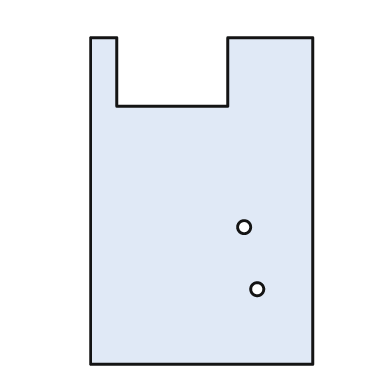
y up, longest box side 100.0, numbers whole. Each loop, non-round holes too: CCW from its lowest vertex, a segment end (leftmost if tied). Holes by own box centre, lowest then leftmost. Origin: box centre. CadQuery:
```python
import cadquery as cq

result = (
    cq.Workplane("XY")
    .moveTo(-34.0, -50.0)
    .lineTo(34.0, -50.0)
    .lineTo(34.0, 50.0)
    .lineTo(8.0, 50.0)
    .lineTo(8.0, 29.0)
    .lineTo(-26.0, 29.0)
    .lineTo(-26.0, 50.0)
    .lineTo(-34.0, 50.0)
    .close()
    .moveTo(17.0, -27.0)
    .circle(2.0)
    .moveTo(13.0, -8.0)
    .circle(2.0)
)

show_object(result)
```